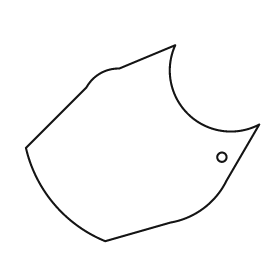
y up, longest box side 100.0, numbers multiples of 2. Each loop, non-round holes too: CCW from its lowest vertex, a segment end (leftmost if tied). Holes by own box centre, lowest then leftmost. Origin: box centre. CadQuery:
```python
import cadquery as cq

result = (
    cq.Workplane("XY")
    .moveTo(-16.0, -42.0)
    .lineTo(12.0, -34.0)
    .threePointArc((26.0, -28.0), (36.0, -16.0))
    .lineTo(50.0, 8.0)
    .threePointArc((20.0, 12.0), (14.0, 42.0))
    .lineTo(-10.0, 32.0)
    .threePointArc((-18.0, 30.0), (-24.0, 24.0))
    .lineTo(-50.0, -2.0)
    .threePointArc((-38.0, -26.0), (-16.0, -42.0))
    .close()
    .moveTo(34.0, -6.0)
    .circle(2.0)
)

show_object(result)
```